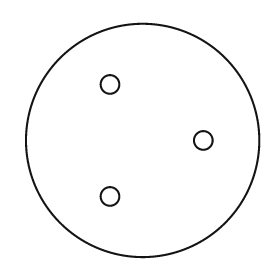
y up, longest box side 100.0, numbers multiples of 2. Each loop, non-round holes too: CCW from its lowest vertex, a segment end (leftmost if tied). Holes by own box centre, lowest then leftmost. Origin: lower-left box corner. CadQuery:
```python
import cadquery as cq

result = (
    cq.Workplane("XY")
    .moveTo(50.0, 50.0)
    .circle(50.0)
    .moveTo(36.0, 26.0)
    .circle(4.0)
    .moveTo(76.0, 50.0)
    .circle(4.0)
    .moveTo(36.0, 74.0)
    .circle(4.0)
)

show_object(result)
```